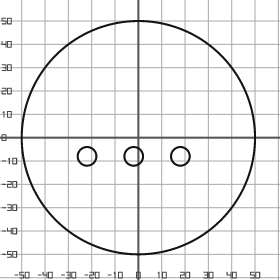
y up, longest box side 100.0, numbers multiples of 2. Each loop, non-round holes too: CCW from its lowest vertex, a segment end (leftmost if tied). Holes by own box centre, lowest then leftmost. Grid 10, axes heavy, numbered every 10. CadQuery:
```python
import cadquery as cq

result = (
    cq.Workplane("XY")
    .moveTo(0.0, 0.0)
    .circle(50.0)
    .moveTo(-22.0, -8.0)
    .circle(4.0)
    .moveTo(-2.0, -8.0)
    .circle(4.0)
    .moveTo(18.0, -8.0)
    .circle(4.0)
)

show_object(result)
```